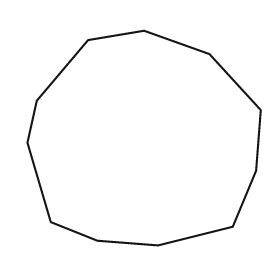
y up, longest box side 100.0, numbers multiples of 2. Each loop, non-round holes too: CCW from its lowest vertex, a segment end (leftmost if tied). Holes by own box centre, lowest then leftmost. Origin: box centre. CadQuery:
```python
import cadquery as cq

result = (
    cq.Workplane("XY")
    .moveTo(6.0, -46.0)
    .lineTo(38.0, -38.0)
    .lineTo(48.0, -14.0)
    .lineTo(50.0, 12.0)
    .lineTo(28.0, 36.0)
    .lineTo(0.0, 46.0)
    .lineTo(-24.0, 42.0)
    .lineTo(-46.0, 16.0)
    .lineTo(-50.0, -2.0)
    .lineTo(-40.0, -36.0)
    .lineTo(-20.0, -44.0)
    .close()
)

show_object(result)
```